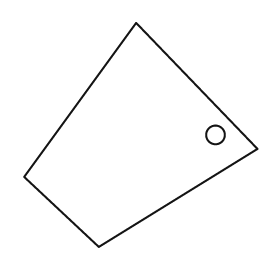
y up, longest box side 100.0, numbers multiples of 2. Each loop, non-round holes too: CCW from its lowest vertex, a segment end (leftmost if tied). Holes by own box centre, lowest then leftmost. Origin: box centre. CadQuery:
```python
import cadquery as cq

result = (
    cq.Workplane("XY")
    .moveTo(-18.0, -48.0)
    .lineTo(50.0, -6.0)
    .lineTo(-2.0, 48.0)
    .lineTo(-50.0, -18.0)
    .close()
    .moveTo(32.0, 0.0)
    .circle(4.0)
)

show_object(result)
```